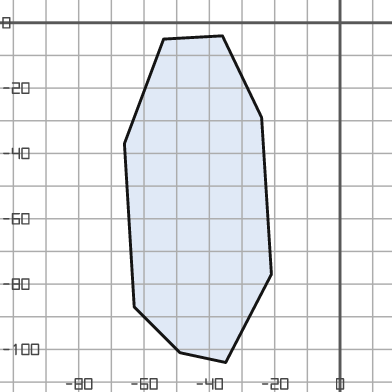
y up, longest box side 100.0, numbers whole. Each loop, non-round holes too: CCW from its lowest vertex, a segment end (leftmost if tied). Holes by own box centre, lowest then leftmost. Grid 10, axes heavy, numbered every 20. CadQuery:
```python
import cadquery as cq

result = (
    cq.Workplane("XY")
    .moveTo(-35.0, -104.0)
    .lineTo(-21.0, -77.0)
    .lineTo(-24.0, -29.0)
    .lineTo(-36.0, -4.0)
    .lineTo(-54.0, -5.0)
    .lineTo(-66.0, -37.0)
    .lineTo(-63.0, -87.0)
    .lineTo(-49.0, -101.0)
    .close()
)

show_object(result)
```